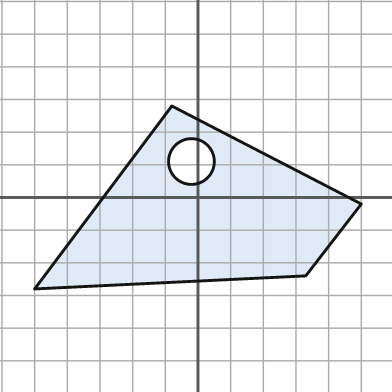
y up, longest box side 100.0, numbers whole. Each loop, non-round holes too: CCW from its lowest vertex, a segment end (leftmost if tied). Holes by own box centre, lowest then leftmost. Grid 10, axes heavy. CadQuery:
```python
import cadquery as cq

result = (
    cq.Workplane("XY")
    .moveTo(-50.0, -28.0)
    .lineTo(33.0, -24.0)
    .lineTo(50.0, -2.0)
    .lineTo(-8.0, 28.0)
    .close()
    .moveTo(-2.0, 11.0)
    .circle(7.0)
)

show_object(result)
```